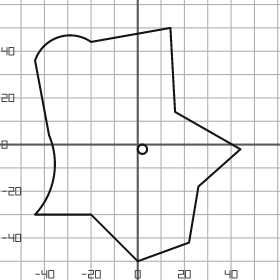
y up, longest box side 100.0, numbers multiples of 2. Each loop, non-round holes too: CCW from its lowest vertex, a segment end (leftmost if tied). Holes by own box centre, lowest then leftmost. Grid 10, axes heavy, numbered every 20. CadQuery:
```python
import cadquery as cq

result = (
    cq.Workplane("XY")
    .moveTo(0.0, -50.0)
    .lineTo(22.0, -42.0)
    .lineTo(26.0, -18.0)
    .lineTo(44.0, -2.0)
    .lineTo(16.0, 14.0)
    .lineTo(14.0, 50.0)
    .lineTo(-20.0, 44.0)
    .threePointArc((-34.0, 46.0), (-44.0, 36.0))
    .lineTo(-38.0, 4.0)
    .threePointArc((-36.0, -14.0), (-44.0, -30.0))
    .lineTo(-20.0, -30.0)
    .close()
    .moveTo(2.0, -2.0)
    .circle(2.0)
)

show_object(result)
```